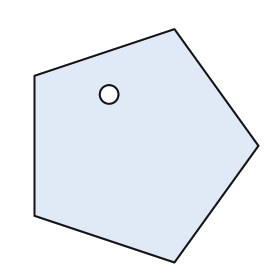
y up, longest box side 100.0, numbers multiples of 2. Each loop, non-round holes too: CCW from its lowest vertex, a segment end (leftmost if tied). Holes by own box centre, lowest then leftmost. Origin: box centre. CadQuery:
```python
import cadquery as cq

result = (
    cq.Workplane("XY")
    .moveTo(12.0, -50.0)
    .lineTo(48.0, 0.0)
    .lineTo(12.0, 50.0)
    .lineTo(-48.0, 30.0)
    .lineTo(-48.0, -30.0)
    .close()
    .moveTo(-16.0, 22.0)
    .circle(4.0)
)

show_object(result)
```